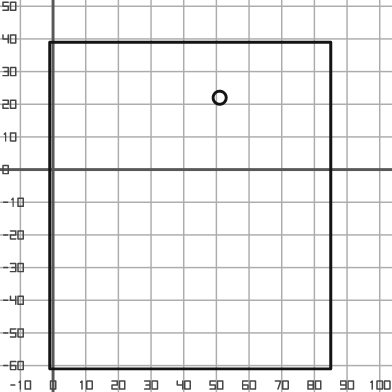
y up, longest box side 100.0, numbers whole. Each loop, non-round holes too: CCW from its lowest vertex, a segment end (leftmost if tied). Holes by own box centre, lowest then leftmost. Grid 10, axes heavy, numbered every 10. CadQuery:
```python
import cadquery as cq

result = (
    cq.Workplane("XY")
    .moveTo(-1.0, -61.0)
    .lineTo(85.0, -61.0)
    .lineTo(85.0, 39.0)
    .lineTo(-1.0, 39.0)
    .close()
    .moveTo(51.0, 22.0)
    .circle(2.0)
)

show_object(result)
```